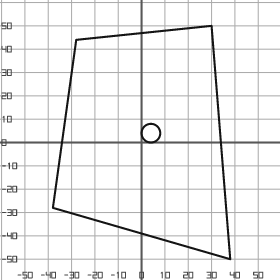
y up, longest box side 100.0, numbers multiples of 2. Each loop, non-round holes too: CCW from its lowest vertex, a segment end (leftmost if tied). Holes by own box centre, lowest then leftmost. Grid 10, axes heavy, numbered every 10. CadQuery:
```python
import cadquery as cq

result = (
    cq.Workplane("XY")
    .moveTo(38.0, -50.0)
    .lineTo(30.0, 50.0)
    .lineTo(-28.0, 44.0)
    .lineTo(-38.0, -28.0)
    .close()
    .moveTo(4.0, 4.0)
    .circle(4.0)
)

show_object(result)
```